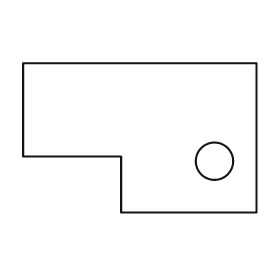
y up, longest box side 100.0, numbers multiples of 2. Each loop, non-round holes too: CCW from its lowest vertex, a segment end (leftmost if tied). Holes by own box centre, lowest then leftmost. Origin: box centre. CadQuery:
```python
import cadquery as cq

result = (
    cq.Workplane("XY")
    .moveTo(-8.0, -32.0)
    .lineTo(50.0, -32.0)
    .lineTo(50.0, 32.0)
    .lineTo(-50.0, 32.0)
    .lineTo(-50.0, -8.0)
    .lineTo(-8.0, -8.0)
    .close()
    .moveTo(32.0, -10.0)
    .circle(8.0)
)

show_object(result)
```